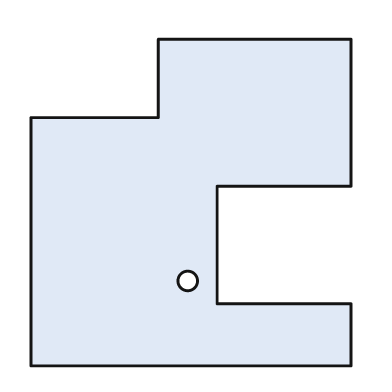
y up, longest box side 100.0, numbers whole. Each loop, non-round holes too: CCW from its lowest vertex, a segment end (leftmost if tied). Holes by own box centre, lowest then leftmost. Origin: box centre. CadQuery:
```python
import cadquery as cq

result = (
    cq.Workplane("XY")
    .moveTo(-49.0, -50.0)
    .lineTo(49.0, -50.0)
    .lineTo(49.0, -31.0)
    .lineTo(8.0, -31.0)
    .lineTo(8.0, 5.0)
    .lineTo(49.0, 5.0)
    .lineTo(49.0, 50.0)
    .lineTo(-10.0, 50.0)
    .lineTo(-10.0, 26.0)
    .lineTo(-49.0, 26.0)
    .close()
    .moveTo(-1.0, -24.0)
    .circle(3.0)
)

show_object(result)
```